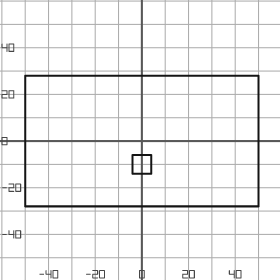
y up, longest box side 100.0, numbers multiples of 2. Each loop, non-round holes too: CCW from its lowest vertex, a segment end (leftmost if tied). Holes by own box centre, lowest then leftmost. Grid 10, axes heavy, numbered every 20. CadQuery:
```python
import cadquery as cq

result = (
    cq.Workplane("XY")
    .moveTo(-50.0, -28.0)
    .lineTo(50.0, -28.0)
    .lineTo(50.0, 28.0)
    .lineTo(-50.0, 28.0)
    .close()
    .moveTo(-4.0, -14.0)
    .lineTo(4.0, -14.0)
    .lineTo(4.0, -6.0)
    .lineTo(-4.0, -6.0)
    .close()
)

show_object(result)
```